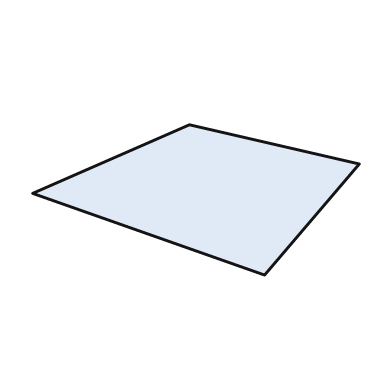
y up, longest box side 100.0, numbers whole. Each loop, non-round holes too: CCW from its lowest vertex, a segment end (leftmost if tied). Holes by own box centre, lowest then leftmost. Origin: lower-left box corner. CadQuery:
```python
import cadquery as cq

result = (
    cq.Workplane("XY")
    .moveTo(71.0, 0.0)
    .lineTo(100.0, 34.0)
    .lineTo(48.0, 46.0)
    .lineTo(0.0, 25.0)
    .close()
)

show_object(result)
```